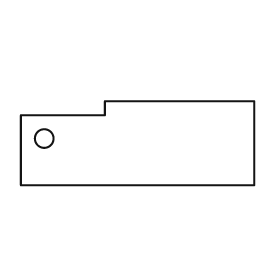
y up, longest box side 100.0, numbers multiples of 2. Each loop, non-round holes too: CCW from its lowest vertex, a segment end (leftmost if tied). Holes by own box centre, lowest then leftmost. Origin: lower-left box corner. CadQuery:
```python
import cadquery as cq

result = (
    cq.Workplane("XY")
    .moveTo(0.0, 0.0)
    .lineTo(100.0, 0.0)
    .lineTo(100.0, 36.0)
    .lineTo(36.0, 36.0)
    .lineTo(36.0, 30.0)
    .lineTo(0.0, 30.0)
    .close()
    .moveTo(10.0, 20.0)
    .circle(4.0)
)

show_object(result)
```